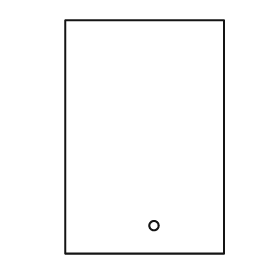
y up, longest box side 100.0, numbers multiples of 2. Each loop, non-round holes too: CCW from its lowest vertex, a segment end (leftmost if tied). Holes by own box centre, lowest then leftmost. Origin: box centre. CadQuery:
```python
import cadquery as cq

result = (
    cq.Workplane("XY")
    .moveTo(-34.0, -50.0)
    .lineTo(34.0, -50.0)
    .lineTo(34.0, 50.0)
    .lineTo(-34.0, 50.0)
    .close()
    .moveTo(4.0, -38.0)
    .circle(2.0)
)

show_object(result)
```